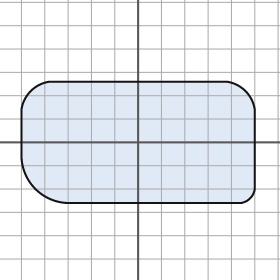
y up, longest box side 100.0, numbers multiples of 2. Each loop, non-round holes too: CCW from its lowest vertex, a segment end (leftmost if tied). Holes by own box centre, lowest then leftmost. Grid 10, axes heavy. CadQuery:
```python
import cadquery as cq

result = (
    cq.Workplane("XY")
    .moveTo(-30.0, -26.0)
    .lineTo(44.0, -26.0)
    .threePointArc((48.0, -24.0), (50.0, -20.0))
    .lineTo(50.0, 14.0)
    .threePointArc((46.0, 22.0), (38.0, 26.0))
    .lineTo(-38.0, 26.0)
    .threePointArc((-46.0, 22.0), (-50.0, 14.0))
    .lineTo(-50.0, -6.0)
    .threePointArc((-44.0, -20.0), (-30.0, -26.0))
    .close()
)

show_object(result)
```